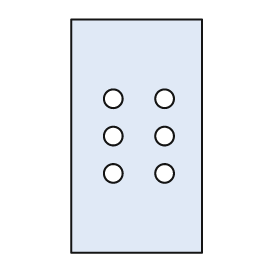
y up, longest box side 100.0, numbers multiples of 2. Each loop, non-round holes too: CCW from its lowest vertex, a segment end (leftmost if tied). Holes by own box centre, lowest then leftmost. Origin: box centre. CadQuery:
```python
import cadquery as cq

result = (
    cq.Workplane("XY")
    .moveTo(-28.0, -50.0)
    .lineTo(28.0, -50.0)
    .lineTo(28.0, 50.0)
    .lineTo(-28.0, 50.0)
    .close()
    .moveTo(-10.0, -16.0)
    .circle(4.0)
    .moveTo(12.0, -16.0)
    .circle(4.0)
    .moveTo(-10.0, 0.0)
    .circle(4.0)
    .moveTo(12.0, 0.0)
    .circle(4.0)
    .moveTo(-10.0, 16.0)
    .circle(4.0)
    .moveTo(12.0, 16.0)
    .circle(4.0)
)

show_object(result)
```